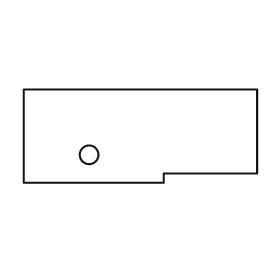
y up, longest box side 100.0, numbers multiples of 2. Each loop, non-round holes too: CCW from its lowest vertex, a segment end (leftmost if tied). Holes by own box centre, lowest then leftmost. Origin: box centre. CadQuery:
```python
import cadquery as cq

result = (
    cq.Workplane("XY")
    .moveTo(-50.0, -20.0)
    .lineTo(10.0, -20.0)
    .lineTo(10.0, -16.0)
    .lineTo(50.0, -16.0)
    .lineTo(50.0, 20.0)
    .lineTo(-50.0, 20.0)
    .close()
    .moveTo(-22.0, -8.0)
    .circle(4.0)
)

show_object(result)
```